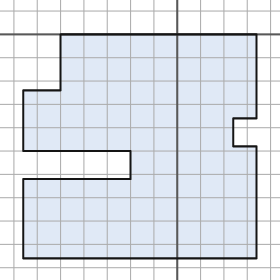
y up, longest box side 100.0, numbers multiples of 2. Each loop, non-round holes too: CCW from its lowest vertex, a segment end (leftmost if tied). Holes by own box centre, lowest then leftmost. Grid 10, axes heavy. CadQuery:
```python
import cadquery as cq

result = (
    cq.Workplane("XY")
    .moveTo(-66.0, -96.0)
    .lineTo(34.0, -96.0)
    .lineTo(34.0, -48.0)
    .lineTo(24.0, -48.0)
    .lineTo(24.0, -36.0)
    .lineTo(34.0, -36.0)
    .lineTo(34.0, 0.0)
    .lineTo(-50.0, 0.0)
    .lineTo(-50.0, -24.0)
    .lineTo(-66.0, -24.0)
    .lineTo(-66.0, -50.0)
    .lineTo(-20.0, -50.0)
    .lineTo(-20.0, -62.0)
    .lineTo(-66.0, -62.0)
    .close()
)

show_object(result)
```